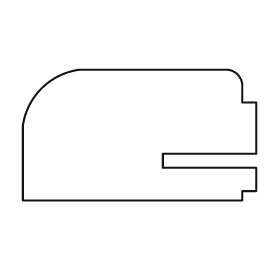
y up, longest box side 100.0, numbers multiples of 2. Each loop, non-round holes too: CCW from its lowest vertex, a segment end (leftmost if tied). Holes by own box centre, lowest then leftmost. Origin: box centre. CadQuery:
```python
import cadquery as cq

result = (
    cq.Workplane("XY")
    .moveTo(-50.0, -28.0)
    .lineTo(44.0, -28.0)
    .lineTo(44.0, -24.0)
    .lineTo(50.0, -24.0)
    .lineTo(50.0, -14.0)
    .lineTo(10.0, -14.0)
    .lineTo(10.0, -8.0)
    .lineTo(50.0, -8.0)
    .lineTo(50.0, 14.0)
    .lineTo(44.0, 14.0)
    .lineTo(44.0, 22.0)
    .threePointArc((42.0, 26.0), (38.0, 28.0))
    .lineTo(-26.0, 28.0)
    .threePointArc((-42.0, 20.0), (-50.0, 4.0))
    .close()
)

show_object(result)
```